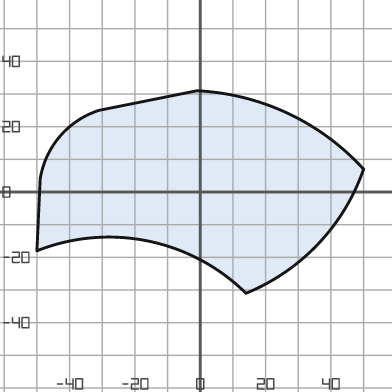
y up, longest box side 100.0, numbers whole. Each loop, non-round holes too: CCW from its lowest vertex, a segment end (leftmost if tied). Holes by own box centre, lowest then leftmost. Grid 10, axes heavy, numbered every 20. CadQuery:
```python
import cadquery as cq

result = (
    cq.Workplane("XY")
    .moveTo(14.0, -31.0)
    .threePointArc((36.0, -16.0), (50.0, 7.0))
    .threePointArc((27.0, 24.0), (-1.0, 31.0))
    .lineTo(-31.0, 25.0)
    .threePointArc((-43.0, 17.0), (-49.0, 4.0))
    .lineTo(-50.0, -18.0)
    .threePointArc((-16.0, -15.0), (14.0, -31.0))
    .close()
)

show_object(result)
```